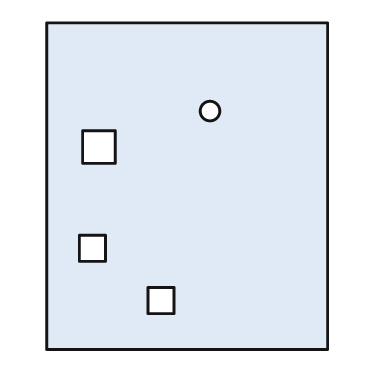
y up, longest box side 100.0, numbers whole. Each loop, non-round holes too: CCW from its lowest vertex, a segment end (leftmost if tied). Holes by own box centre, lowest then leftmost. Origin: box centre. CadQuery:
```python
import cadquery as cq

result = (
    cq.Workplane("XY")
    .moveTo(-43.0, -50.0)
    .lineTo(43.0, -50.0)
    .lineTo(43.0, 50.0)
    .lineTo(-43.0, 50.0)
    .close()
    .moveTo(-12.0, -39.0)
    .lineTo(-4.0, -39.0)
    .lineTo(-4.0, -31.0)
    .lineTo(-12.0, -31.0)
    .close()
    .moveTo(-33.0, -23.0)
    .lineTo(-25.0, -23.0)
    .lineTo(-25.0, -15.0)
    .lineTo(-33.0, -15.0)
    .close()
    .moveTo(-32.0, 7.0)
    .lineTo(-22.0, 7.0)
    .lineTo(-22.0, 17.0)
    .lineTo(-32.0, 17.0)
    .close()
    .moveTo(7.0, 23.0)
    .circle(3.0)
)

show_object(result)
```